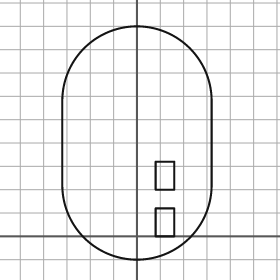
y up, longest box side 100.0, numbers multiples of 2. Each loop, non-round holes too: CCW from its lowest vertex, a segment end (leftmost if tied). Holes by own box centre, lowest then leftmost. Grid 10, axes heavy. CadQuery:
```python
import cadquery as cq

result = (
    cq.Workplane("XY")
    .moveTo(-32.0, 22.0)
    .threePointArc((0.0, -10.0), (32.0, 22.0))
    .lineTo(32.0, 58.0)
    .threePointArc((0.0, 90.0), (-32.0, 58.0))
    .close()
    .moveTo(8.0, 0.0)
    .lineTo(16.0, 0.0)
    .lineTo(16.0, 12.0)
    .lineTo(8.0, 12.0)
    .close()
    .moveTo(8.0, 20.0)
    .lineTo(16.0, 20.0)
    .lineTo(16.0, 32.0)
    .lineTo(8.0, 32.0)
    .close()
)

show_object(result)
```